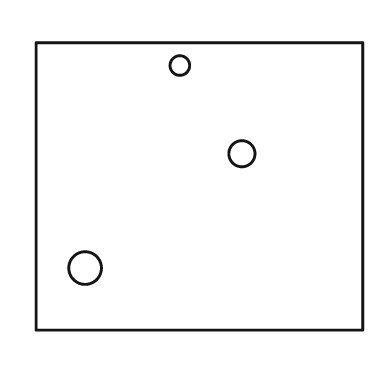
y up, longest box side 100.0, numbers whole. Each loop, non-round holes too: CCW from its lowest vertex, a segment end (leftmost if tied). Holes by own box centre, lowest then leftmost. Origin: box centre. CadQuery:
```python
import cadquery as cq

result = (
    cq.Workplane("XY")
    .moveTo(-50.0, -44.0)
    .lineTo(50.0, -44.0)
    .lineTo(50.0, 44.0)
    .lineTo(-50.0, 44.0)
    .close()
    .moveTo(-35.0, -25.0)
    .circle(5.0)
    .moveTo(13.0, 10.0)
    .circle(4.0)
    .moveTo(-6.0, 37.0)
    .circle(3.0)
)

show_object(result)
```